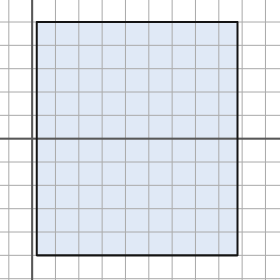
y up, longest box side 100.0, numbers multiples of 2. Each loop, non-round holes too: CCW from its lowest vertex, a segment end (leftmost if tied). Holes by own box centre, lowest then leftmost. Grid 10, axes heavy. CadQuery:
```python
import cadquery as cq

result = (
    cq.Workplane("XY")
    .moveTo(2.0, -50.0)
    .lineTo(88.0, -50.0)
    .lineTo(88.0, 50.0)
    .lineTo(2.0, 50.0)
    .close()
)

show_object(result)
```